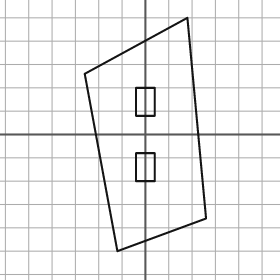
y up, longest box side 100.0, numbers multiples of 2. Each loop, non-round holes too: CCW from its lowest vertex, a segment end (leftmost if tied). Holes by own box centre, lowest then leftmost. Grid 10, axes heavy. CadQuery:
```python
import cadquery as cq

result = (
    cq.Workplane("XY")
    .moveTo(-12.0, -50.0)
    .lineTo(26.0, -36.0)
    .lineTo(18.0, 50.0)
    .lineTo(-26.0, 26.0)
    .close()
    .moveTo(-4.0, -20.0)
    .lineTo(4.0, -20.0)
    .lineTo(4.0, -8.0)
    .lineTo(-4.0, -8.0)
    .close()
    .moveTo(-4.0, 8.0)
    .lineTo(4.0, 8.0)
    .lineTo(4.0, 20.0)
    .lineTo(-4.0, 20.0)
    .close()
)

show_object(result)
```